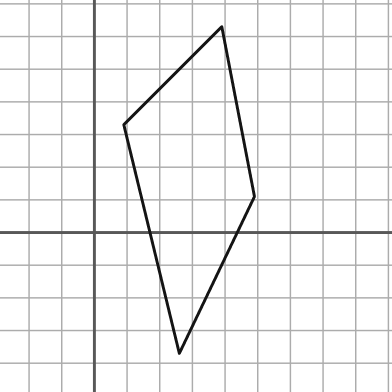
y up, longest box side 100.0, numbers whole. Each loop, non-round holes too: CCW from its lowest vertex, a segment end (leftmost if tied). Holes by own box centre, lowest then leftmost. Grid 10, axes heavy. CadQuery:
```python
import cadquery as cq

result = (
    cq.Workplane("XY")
    .moveTo(26.0, -37.0)
    .lineTo(49.0, 11.0)
    .lineTo(39.0, 63.0)
    .lineTo(9.0, 33.0)
    .close()
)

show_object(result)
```